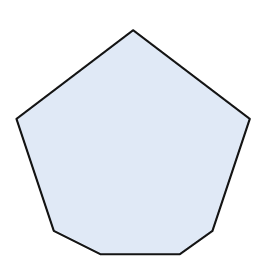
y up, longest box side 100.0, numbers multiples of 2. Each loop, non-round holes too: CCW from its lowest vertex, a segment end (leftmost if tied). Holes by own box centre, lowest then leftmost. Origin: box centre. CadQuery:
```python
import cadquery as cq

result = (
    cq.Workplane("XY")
    .moveTo(-14.0, -48.0)
    .lineTo(20.0, -48.0)
    .lineTo(34.0, -38.0)
    .lineTo(50.0, 10.0)
    .lineTo(0.0, 48.0)
    .lineTo(-50.0, 10.0)
    .lineTo(-34.0, -38.0)
    .close()
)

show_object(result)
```